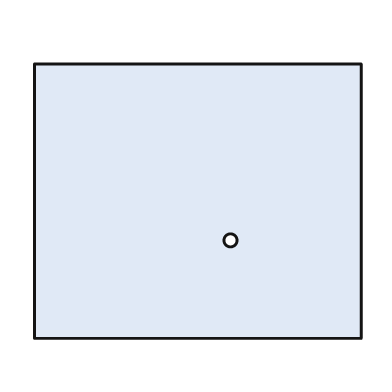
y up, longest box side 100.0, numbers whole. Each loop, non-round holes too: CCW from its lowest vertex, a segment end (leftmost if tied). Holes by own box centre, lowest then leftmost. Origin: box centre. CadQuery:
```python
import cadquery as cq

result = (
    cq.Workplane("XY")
    .moveTo(-50.0, -42.0)
    .lineTo(50.0, -42.0)
    .lineTo(50.0, 42.0)
    .lineTo(-50.0, 42.0)
    .close()
    .moveTo(10.0, -12.0)
    .circle(2.0)
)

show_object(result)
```